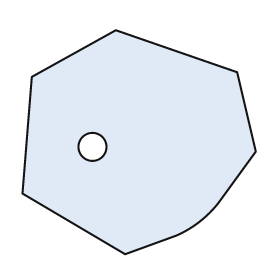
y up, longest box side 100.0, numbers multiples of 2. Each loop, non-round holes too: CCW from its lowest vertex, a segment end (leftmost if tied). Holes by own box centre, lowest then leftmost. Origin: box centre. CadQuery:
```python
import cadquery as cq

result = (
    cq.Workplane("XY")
    .moveTo(-6.0, -48.0)
    .lineTo(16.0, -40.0)
    .threePointArc((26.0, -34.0), (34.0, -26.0))
    .lineTo(50.0, -4.0)
    .lineTo(42.0, 30.0)
    .lineTo(-10.0, 48.0)
    .lineTo(-46.0, 28.0)
    .lineTo(-50.0, -22.0)
    .close()
    .moveTo(-20.0, -2.0)
    .circle(6.0)
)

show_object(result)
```